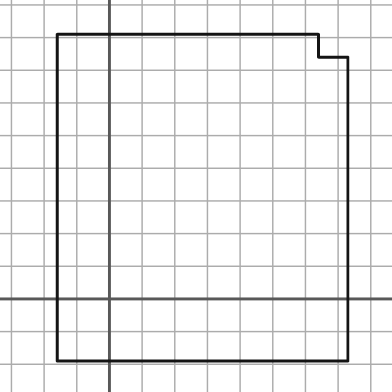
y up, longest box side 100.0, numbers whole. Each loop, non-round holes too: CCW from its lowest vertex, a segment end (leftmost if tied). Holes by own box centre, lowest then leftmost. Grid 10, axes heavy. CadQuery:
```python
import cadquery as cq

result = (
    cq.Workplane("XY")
    .moveTo(-16.0, -19.0)
    .lineTo(73.0, -19.0)
    .lineTo(73.0, 74.0)
    .lineTo(64.0, 74.0)
    .lineTo(64.0, 81.0)
    .lineTo(-16.0, 81.0)
    .close()
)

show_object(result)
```